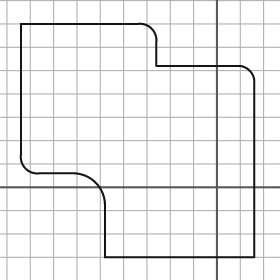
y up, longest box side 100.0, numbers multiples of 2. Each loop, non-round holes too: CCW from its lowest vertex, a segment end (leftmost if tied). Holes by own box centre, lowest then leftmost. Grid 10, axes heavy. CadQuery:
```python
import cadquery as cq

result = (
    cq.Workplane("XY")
    .moveTo(-48.0, -30.0)
    .lineTo(16.0, -30.0)
    .lineTo(16.0, 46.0)
    .threePointArc((14.0, 50.0), (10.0, 52.0))
    .lineTo(-26.0, 52.0)
    .lineTo(-26.0, 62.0)
    .threePointArc((-28.0, 68.0), (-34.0, 70.0))
    .lineTo(-84.0, 70.0)
    .lineTo(-84.0, 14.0)
    .threePointArc((-82.0, 8.0), (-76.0, 6.0))
    .lineTo(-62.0, 6.0)
    .threePointArc((-52.0, 2.0), (-48.0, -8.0))
    .close()
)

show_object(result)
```